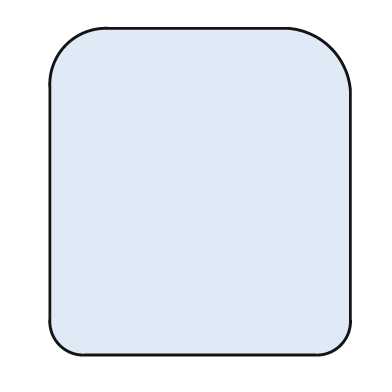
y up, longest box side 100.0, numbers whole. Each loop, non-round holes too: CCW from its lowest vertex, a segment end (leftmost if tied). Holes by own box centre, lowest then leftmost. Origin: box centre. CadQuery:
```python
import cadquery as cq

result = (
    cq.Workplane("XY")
    .moveTo(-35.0, -50.0)
    .lineTo(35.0, -50.0)
    .threePointArc((43.0, -47.0), (46.0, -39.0))
    .lineTo(46.0, 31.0)
    .threePointArc((40.0, 44.0), (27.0, 50.0))
    .lineTo(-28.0, 50.0)
    .threePointArc((-41.0, 45.0), (-46.0, 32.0))
    .lineTo(-46.0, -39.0)
    .threePointArc((-43.0, -47.0), (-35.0, -50.0))
    .close()
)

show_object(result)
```